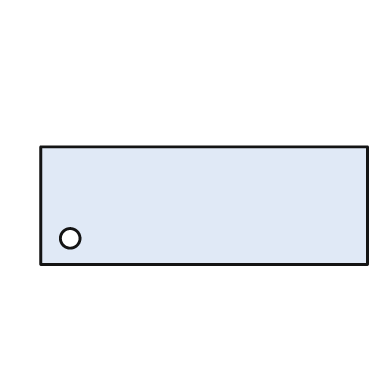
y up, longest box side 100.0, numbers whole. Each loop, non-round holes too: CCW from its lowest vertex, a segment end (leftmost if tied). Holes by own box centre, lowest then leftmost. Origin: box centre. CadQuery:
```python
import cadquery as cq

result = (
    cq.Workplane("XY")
    .moveTo(-50.0, -18.0)
    .lineTo(50.0, -18.0)
    .lineTo(50.0, 18.0)
    .lineTo(-50.0, 18.0)
    .close()
    .moveTo(-41.0, -10.0)
    .circle(3.0)
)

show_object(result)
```